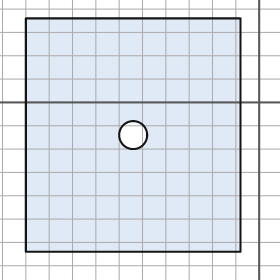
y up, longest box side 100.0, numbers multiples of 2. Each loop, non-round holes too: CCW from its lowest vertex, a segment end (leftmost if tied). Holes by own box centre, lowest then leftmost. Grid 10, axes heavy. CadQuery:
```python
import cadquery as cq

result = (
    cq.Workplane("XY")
    .moveTo(-100.0, -64.0)
    .lineTo(-8.0, -64.0)
    .lineTo(-8.0, 36.0)
    .lineTo(-100.0, 36.0)
    .close()
    .moveTo(-54.0, -14.0)
    .circle(6.0)
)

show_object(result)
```